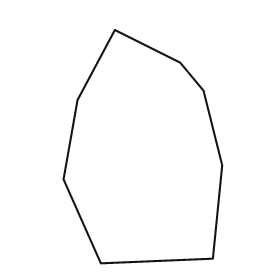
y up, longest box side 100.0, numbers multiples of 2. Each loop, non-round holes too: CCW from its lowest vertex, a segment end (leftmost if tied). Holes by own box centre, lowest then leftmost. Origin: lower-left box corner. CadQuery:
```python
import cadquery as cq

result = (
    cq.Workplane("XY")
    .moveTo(16.0, 0.0)
    .lineTo(64.0, 2.0)
    .lineTo(68.0, 42.0)
    .lineTo(60.0, 74.0)
    .lineTo(50.0, 86.0)
    .lineTo(22.0, 100.0)
    .lineTo(6.0, 70.0)
    .lineTo(0.0, 36.0)
    .close()
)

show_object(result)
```